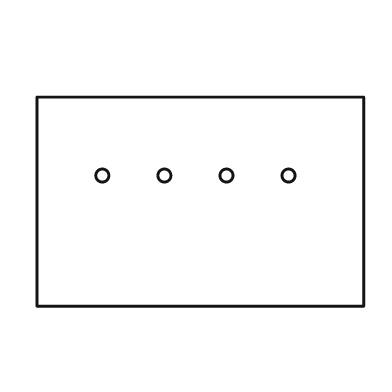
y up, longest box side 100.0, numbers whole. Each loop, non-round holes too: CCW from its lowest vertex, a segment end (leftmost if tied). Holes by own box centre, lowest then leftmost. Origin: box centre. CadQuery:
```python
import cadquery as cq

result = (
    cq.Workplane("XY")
    .moveTo(-50.0, -32.0)
    .lineTo(50.0, -32.0)
    .lineTo(50.0, 32.0)
    .lineTo(-50.0, 32.0)
    .close()
    .moveTo(-30.0, 8.0)
    .circle(2.0)
    .moveTo(-11.0, 8.0)
    .circle(2.0)
    .moveTo(8.0, 8.0)
    .circle(2.0)
    .moveTo(27.0, 8.0)
    .circle(2.0)
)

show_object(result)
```